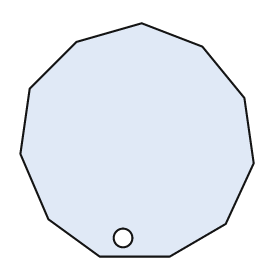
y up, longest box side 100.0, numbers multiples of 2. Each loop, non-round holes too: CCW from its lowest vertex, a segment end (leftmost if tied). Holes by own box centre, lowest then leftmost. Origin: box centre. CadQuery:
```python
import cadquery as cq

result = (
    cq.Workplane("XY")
    .moveTo(-16.0, -50.0)
    .lineTo(14.0, -50.0)
    .lineTo(38.0, -36.0)
    .lineTo(50.0, -10.0)
    .lineTo(46.0, 18.0)
    .lineTo(28.0, 40.0)
    .lineTo(2.0, 50.0)
    .lineTo(-26.0, 42.0)
    .lineTo(-46.0, 22.0)
    .lineTo(-50.0, -6.0)
    .lineTo(-38.0, -34.0)
    .close()
    .moveTo(-6.0, -42.0)
    .circle(4.0)
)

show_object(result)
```